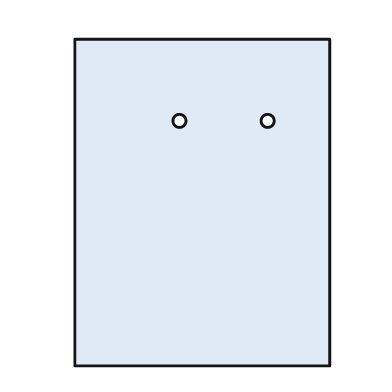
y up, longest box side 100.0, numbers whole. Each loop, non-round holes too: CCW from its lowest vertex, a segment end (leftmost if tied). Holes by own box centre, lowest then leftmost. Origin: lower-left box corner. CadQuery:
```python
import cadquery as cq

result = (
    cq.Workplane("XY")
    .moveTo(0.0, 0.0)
    .lineTo(78.0, 0.0)
    .lineTo(78.0, 100.0)
    .lineTo(0.0, 100.0)
    .close()
    .moveTo(32.0, 75.0)
    .circle(2.0)
    .moveTo(59.0, 75.0)
    .circle(2.0)
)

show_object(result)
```